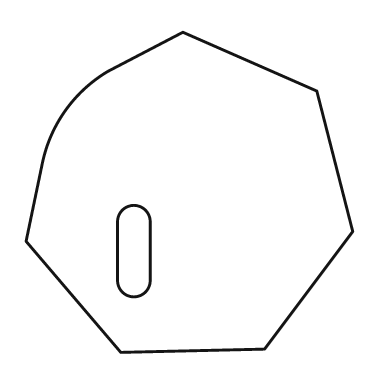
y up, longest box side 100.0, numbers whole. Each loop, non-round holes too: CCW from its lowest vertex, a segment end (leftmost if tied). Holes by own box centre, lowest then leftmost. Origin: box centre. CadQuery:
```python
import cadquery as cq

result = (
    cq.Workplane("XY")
    .moveTo(-21.0, -49.0)
    .lineTo(23.0, -48.0)
    .lineTo(50.0, -12.0)
    .lineTo(39.0, 31.0)
    .lineTo(-2.0, 49.0)
    .lineTo(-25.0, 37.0)
    .threePointArc((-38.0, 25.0), (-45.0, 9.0))
    .lineTo(-50.0, -15.0)
    .close()
    .moveTo(-22.0, -27.0)
    .threePointArc((-17.0, -32.0), (-12.0, -27.0))
    .lineTo(-12.0, -9.0)
    .threePointArc((-17.0, -4.0), (-22.0, -9.0))
    .close()
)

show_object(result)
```